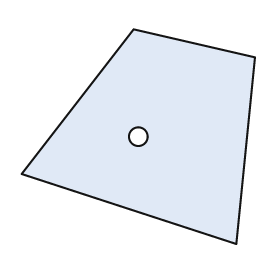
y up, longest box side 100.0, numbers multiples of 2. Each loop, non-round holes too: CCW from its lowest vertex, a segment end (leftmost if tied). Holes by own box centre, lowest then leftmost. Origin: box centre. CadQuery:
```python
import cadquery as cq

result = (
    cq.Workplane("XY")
    .moveTo(42.0, -46.0)
    .lineTo(50.0, 34.0)
    .lineTo(-2.0, 46.0)
    .lineTo(-50.0, -16.0)
    .close()
    .moveTo(0.0, 0.0)
    .circle(4.0)
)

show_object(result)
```